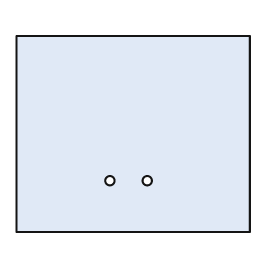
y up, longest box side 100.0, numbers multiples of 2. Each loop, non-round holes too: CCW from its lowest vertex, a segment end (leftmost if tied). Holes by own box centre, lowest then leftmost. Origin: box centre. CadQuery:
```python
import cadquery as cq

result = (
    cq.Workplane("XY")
    .moveTo(-50.0, -42.0)
    .lineTo(50.0, -42.0)
    .lineTo(50.0, 42.0)
    .lineTo(-50.0, 42.0)
    .close()
    .moveTo(-10.0, -20.0)
    .circle(2.0)
    .moveTo(6.0, -20.0)
    .circle(2.0)
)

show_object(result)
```